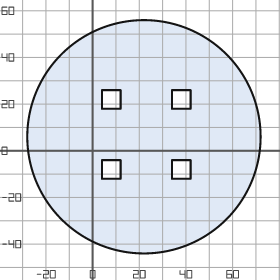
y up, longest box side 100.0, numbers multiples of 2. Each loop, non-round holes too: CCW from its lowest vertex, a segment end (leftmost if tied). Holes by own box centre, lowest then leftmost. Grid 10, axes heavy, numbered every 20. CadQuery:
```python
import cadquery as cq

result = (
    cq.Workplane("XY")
    .moveTo(22.0, 6.0)
    .circle(50.0)
    .moveTo(4.0, -12.0)
    .lineTo(12.0, -12.0)
    .lineTo(12.0, -4.0)
    .lineTo(4.0, -4.0)
    .close()
    .moveTo(34.0, -12.0)
    .lineTo(42.0, -12.0)
    .lineTo(42.0, -4.0)
    .lineTo(34.0, -4.0)
    .close()
    .moveTo(4.0, 18.0)
    .lineTo(12.0, 18.0)
    .lineTo(12.0, 26.0)
    .lineTo(4.0, 26.0)
    .close()
    .moveTo(34.0, 18.0)
    .lineTo(42.0, 18.0)
    .lineTo(42.0, 26.0)
    .lineTo(34.0, 26.0)
    .close()
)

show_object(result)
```